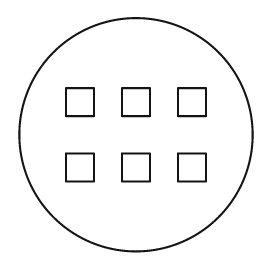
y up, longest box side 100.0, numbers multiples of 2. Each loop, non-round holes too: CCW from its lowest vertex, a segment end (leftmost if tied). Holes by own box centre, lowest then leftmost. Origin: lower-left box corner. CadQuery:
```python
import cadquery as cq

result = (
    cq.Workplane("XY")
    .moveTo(50.0, 50.0)
    .circle(50.0)
    .moveTo(20.0, 30.0)
    .lineTo(32.0, 30.0)
    .lineTo(32.0, 42.0)
    .lineTo(20.0, 42.0)
    .close()
    .moveTo(44.0, 30.0)
    .lineTo(56.0, 30.0)
    .lineTo(56.0, 42.0)
    .lineTo(44.0, 42.0)
    .close()
    .moveTo(68.0, 30.0)
    .lineTo(80.0, 30.0)
    .lineTo(80.0, 42.0)
    .lineTo(68.0, 42.0)
    .close()
    .moveTo(20.0, 58.0)
    .lineTo(32.0, 58.0)
    .lineTo(32.0, 70.0)
    .lineTo(20.0, 70.0)
    .close()
    .moveTo(44.0, 58.0)
    .lineTo(56.0, 58.0)
    .lineTo(56.0, 70.0)
    .lineTo(44.0, 70.0)
    .close()
    .moveTo(68.0, 58.0)
    .lineTo(80.0, 58.0)
    .lineTo(80.0, 70.0)
    .lineTo(68.0, 70.0)
    .close()
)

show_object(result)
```